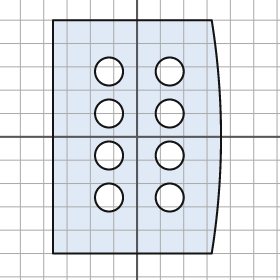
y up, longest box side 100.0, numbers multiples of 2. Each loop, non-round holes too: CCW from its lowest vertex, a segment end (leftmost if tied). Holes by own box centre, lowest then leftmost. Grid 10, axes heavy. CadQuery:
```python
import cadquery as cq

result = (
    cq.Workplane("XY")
    .moveTo(-36.0, -50.0)
    .lineTo(32.0, -50.0)
    .threePointArc((36.0, 0.0), (32.0, 50.0))
    .lineTo(-36.0, 50.0)
    .close()
    .moveTo(-12.0, -26.0)
    .circle(6.0)
    .moveTo(14.0, -26.0)
    .circle(6.0)
    .moveTo(-12.0, -8.0)
    .circle(6.0)
    .moveTo(14.0, -8.0)
    .circle(6.0)
    .moveTo(-12.0, 10.0)
    .circle(6.0)
    .moveTo(14.0, 10.0)
    .circle(6.0)
    .moveTo(-12.0, 28.0)
    .circle(6.0)
    .moveTo(14.0, 28.0)
    .circle(6.0)
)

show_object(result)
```